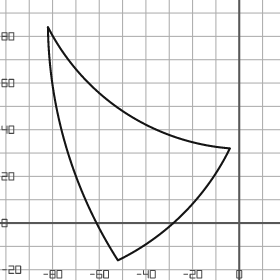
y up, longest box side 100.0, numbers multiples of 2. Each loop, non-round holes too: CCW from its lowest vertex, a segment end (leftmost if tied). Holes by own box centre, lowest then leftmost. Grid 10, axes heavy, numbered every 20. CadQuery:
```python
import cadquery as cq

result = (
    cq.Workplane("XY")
    .moveTo(-52.0, -16.0)
    .threePointArc((-24.0, 4.0), (-4.0, 32.0))
    .threePointArc((-50.0, 48.0), (-82.0, 84.0))
    .threePointArc((-74.0, 32.0), (-52.0, -16.0))
    .close()
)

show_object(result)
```